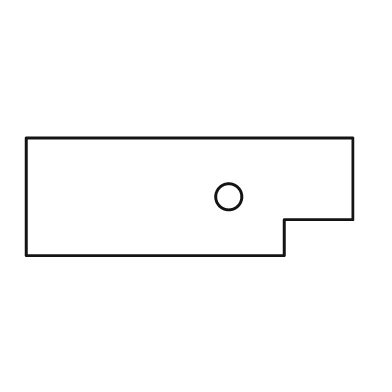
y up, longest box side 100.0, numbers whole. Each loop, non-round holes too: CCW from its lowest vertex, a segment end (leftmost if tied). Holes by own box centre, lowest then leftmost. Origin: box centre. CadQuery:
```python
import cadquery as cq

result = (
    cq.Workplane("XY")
    .moveTo(-50.0, -18.0)
    .lineTo(29.0, -18.0)
    .lineTo(29.0, -7.0)
    .lineTo(50.0, -7.0)
    .lineTo(50.0, 18.0)
    .lineTo(-50.0, 18.0)
    .close()
    .moveTo(12.0, 0.0)
    .circle(4.0)
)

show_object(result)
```